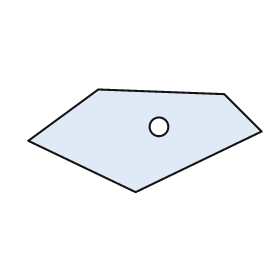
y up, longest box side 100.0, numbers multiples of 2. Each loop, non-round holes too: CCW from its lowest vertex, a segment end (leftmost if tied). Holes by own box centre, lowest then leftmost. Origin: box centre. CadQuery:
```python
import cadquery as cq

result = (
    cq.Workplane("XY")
    .moveTo(-4.0, -22.0)
    .lineTo(50.0, 4.0)
    .lineTo(34.0, 20.0)
    .lineTo(-20.0, 22.0)
    .lineTo(-50.0, 0.0)
    .close()
    .moveTo(6.0, 6.0)
    .circle(4.0)
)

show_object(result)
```